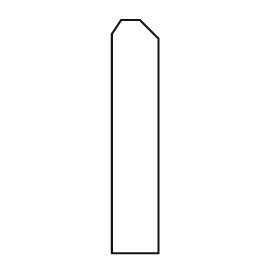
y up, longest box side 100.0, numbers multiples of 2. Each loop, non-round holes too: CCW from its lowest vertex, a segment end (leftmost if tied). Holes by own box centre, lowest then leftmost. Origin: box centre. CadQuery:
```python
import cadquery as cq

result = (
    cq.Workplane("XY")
    .moveTo(-10.0, -50.0)
    .lineTo(10.0, -50.0)
    .lineTo(10.0, 42.0)
    .lineTo(2.0, 50.0)
    .lineTo(-6.0, 50.0)
    .lineTo(-10.0, 44.0)
    .close()
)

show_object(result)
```